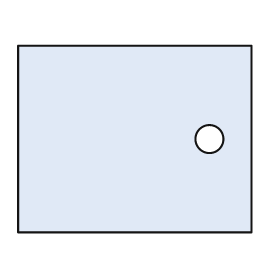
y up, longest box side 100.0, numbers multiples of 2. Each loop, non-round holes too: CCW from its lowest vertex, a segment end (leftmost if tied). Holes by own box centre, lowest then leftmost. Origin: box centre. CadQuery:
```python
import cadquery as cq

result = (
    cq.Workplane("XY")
    .moveTo(-50.0, -40.0)
    .lineTo(50.0, -40.0)
    .lineTo(50.0, 40.0)
    .lineTo(-50.0, 40.0)
    .close()
    .moveTo(32.0, 0.0)
    .circle(6.0)
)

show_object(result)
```